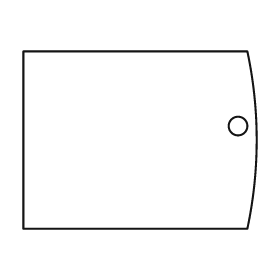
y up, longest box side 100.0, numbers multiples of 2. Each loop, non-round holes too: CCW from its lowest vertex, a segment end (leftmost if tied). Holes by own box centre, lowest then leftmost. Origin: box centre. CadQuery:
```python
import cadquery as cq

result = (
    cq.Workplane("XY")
    .moveTo(-50.0, -38.0)
    .lineTo(46.0, -38.0)
    .threePointArc((50.0, 0.0), (46.0, 38.0))
    .lineTo(-50.0, 38.0)
    .close()
    .moveTo(42.0, 6.0)
    .circle(4.0)
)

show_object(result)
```